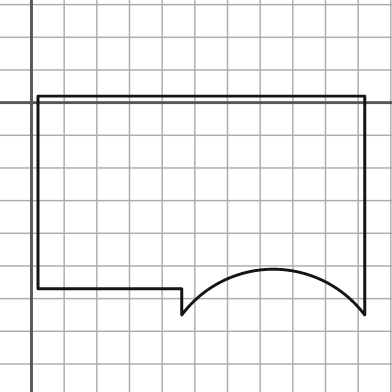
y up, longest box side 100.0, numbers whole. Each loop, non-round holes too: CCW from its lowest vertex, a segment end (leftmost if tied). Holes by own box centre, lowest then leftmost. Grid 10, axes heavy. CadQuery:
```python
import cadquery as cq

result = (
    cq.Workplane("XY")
    .moveTo(46.0, -65.0)
    .threePointArc((74.0, -51.0), (102.0, -65.0))
    .lineTo(102.0, 2.0)
    .lineTo(2.0, 2.0)
    .lineTo(2.0, -57.0)
    .lineTo(46.0, -57.0)
    .close()
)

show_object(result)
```